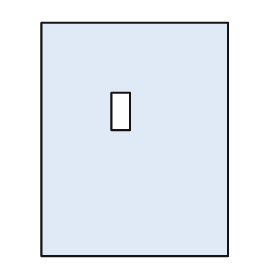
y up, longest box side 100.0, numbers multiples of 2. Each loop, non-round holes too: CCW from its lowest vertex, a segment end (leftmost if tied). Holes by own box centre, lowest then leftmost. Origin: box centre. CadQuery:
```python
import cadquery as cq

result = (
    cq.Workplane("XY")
    .moveTo(-40.0, -50.0)
    .lineTo(40.0, -50.0)
    .lineTo(40.0, 50.0)
    .lineTo(-40.0, 50.0)
    .close()
    .moveTo(-10.0, 4.0)
    .lineTo(-2.0, 4.0)
    .lineTo(-2.0, 20.0)
    .lineTo(-10.0, 20.0)
    .close()
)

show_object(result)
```